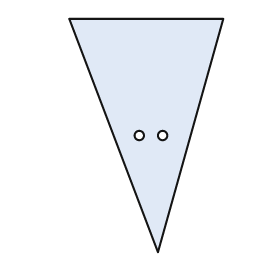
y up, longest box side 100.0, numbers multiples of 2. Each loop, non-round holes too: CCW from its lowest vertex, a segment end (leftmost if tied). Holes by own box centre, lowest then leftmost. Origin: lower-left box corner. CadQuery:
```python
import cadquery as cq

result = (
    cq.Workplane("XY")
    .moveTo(38.0, 0.0)
    .lineTo(66.0, 100.0)
    .lineTo(0.0, 100.0)
    .close()
    .moveTo(30.0, 50.0)
    .circle(2.0)
    .moveTo(40.0, 50.0)
    .circle(2.0)
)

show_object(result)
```